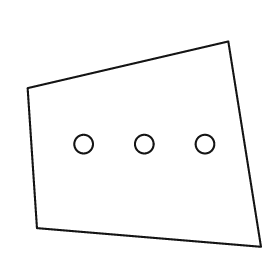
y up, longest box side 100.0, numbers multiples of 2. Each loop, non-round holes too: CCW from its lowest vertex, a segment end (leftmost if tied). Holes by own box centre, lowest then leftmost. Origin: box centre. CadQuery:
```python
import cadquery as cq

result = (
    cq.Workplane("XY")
    .moveTo(50.0, -44.0)
    .lineTo(36.0, 44.0)
    .lineTo(-50.0, 24.0)
    .lineTo(-46.0, -36.0)
    .close()
    .moveTo(-26.0, 0.0)
    .circle(4.0)
    .moveTo(0.0, 0.0)
    .circle(4.0)
    .moveTo(26.0, 0.0)
    .circle(4.0)
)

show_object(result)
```